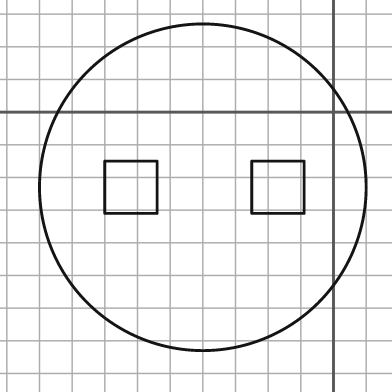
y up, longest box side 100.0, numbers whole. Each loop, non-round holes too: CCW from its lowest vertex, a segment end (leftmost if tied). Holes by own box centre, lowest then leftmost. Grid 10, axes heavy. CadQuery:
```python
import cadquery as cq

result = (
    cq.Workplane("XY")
    .moveTo(-40.0, -23.0)
    .circle(50.0)
    .moveTo(-70.0, -31.0)
    .lineTo(-54.0, -31.0)
    .lineTo(-54.0, -15.0)
    .lineTo(-70.0, -15.0)
    .close()
    .moveTo(-25.0, -31.0)
    .lineTo(-9.0, -31.0)
    .lineTo(-9.0, -15.0)
    .lineTo(-25.0, -15.0)
    .close()
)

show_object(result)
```